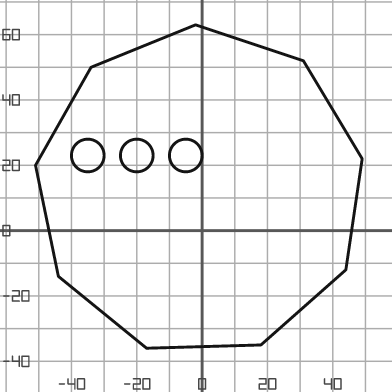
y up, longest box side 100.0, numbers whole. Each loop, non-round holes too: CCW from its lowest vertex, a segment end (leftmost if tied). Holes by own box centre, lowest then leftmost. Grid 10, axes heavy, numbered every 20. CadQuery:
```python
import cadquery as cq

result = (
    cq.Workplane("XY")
    .moveTo(-17.0, -36.0)
    .lineTo(18.0, -35.0)
    .lineTo(44.0, -12.0)
    .lineTo(49.0, 22.0)
    .lineTo(31.0, 52.0)
    .lineTo(-2.0, 63.0)
    .lineTo(-34.0, 50.0)
    .lineTo(-51.0, 20.0)
    .lineTo(-44.0, -14.0)
    .close()
    .moveTo(-35.0, 23.0)
    .circle(5.0)
    .moveTo(-20.0, 23.0)
    .circle(5.0)
    .moveTo(-5.0, 23.0)
    .circle(5.0)
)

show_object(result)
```